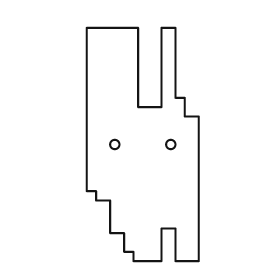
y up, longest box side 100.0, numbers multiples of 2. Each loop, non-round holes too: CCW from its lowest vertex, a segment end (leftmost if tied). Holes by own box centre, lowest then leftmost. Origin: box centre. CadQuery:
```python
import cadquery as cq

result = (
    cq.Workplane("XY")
    .moveTo(-4.0, -50.0)
    .lineTo(8.0, -50.0)
    .lineTo(8.0, -36.0)
    .lineTo(14.0, -36.0)
    .lineTo(14.0, -50.0)
    .lineTo(24.0, -50.0)
    .lineTo(24.0, 12.0)
    .lineTo(18.0, 12.0)
    .lineTo(18.0, 20.0)
    .lineTo(14.0, 20.0)
    .lineTo(14.0, 50.0)
    .lineTo(8.0, 50.0)
    .lineTo(8.0, 16.0)
    .lineTo(-2.0, 16.0)
    .lineTo(-2.0, 50.0)
    .lineTo(-24.0, 50.0)
    .lineTo(-24.0, -20.0)
    .lineTo(-20.0, -20.0)
    .lineTo(-20.0, -24.0)
    .lineTo(-14.0, -24.0)
    .lineTo(-14.0, -38.0)
    .lineTo(-8.0, -38.0)
    .lineTo(-8.0, -46.0)
    .lineTo(-4.0, -46.0)
    .close()
    .moveTo(-12.0, 0.0)
    .circle(2.0)
    .moveTo(12.0, 0.0)
    .circle(2.0)
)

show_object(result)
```